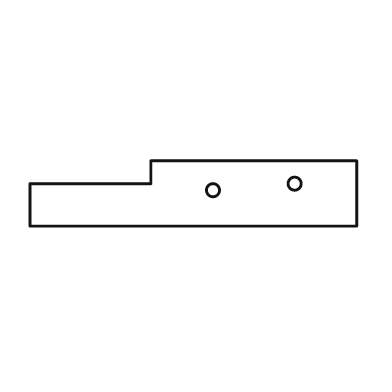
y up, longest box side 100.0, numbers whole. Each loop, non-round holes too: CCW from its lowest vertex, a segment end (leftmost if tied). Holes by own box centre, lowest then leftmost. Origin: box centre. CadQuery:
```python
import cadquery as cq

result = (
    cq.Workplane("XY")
    .moveTo(-50.0, -10.0)
    .lineTo(50.0, -10.0)
    .lineTo(50.0, 10.0)
    .lineTo(-13.0, 10.0)
    .lineTo(-13.0, 3.0)
    .lineTo(-50.0, 3.0)
    .close()
    .moveTo(6.0, 1.0)
    .circle(2.0)
    .moveTo(31.0, 3.0)
    .circle(2.0)
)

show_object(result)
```